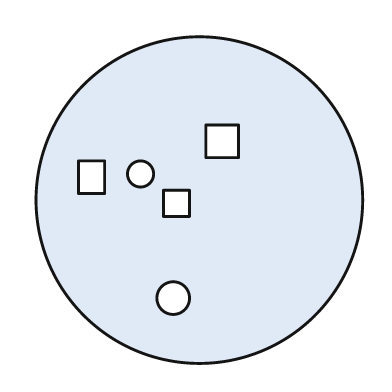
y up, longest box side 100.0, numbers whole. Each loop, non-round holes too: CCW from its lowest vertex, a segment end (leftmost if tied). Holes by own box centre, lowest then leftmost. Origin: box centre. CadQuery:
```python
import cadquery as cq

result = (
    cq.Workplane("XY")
    .moveTo(0.0, 0.0)
    .circle(50.0)
    .moveTo(-8.0, -30.0)
    .circle(5.0)
    .moveTo(-11.0, -5.0)
    .lineTo(-3.0, -5.0)
    .lineTo(-3.0, 3.0)
    .lineTo(-11.0, 3.0)
    .close()
    .moveTo(-37.0, 2.0)
    .lineTo(-29.0, 2.0)
    .lineTo(-29.0, 12.0)
    .lineTo(-37.0, 12.0)
    .close()
    .moveTo(-18.0, 8.0)
    .circle(4.0)
    .moveTo(2.0, 13.0)
    .lineTo(12.0, 13.0)
    .lineTo(12.0, 23.0)
    .lineTo(2.0, 23.0)
    .close()
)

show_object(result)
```